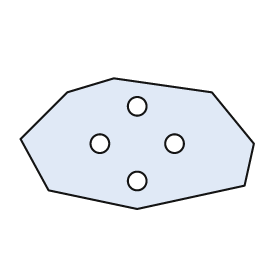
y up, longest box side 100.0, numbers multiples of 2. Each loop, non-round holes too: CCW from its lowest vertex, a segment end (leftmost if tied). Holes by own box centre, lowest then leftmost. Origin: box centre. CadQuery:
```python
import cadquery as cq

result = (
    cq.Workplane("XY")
    .moveTo(0.0, -28.0)
    .lineTo(46.0, -18.0)
    .lineTo(50.0, 0.0)
    .lineTo(32.0, 22.0)
    .lineTo(-10.0, 28.0)
    .lineTo(-30.0, 22.0)
    .lineTo(-50.0, 2.0)
    .lineTo(-38.0, -20.0)
    .close()
    .moveTo(0.0, -16.0)
    .circle(4.0)
    .moveTo(-16.0, 0.0)
    .circle(4.0)
    .moveTo(16.0, 0.0)
    .circle(4.0)
    .moveTo(0.0, 16.0)
    .circle(4.0)
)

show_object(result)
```